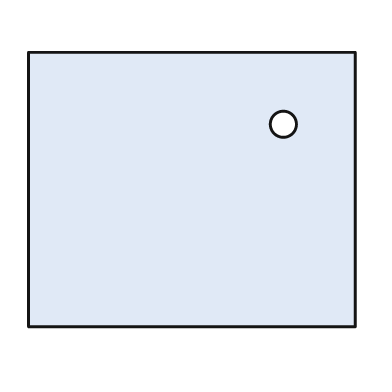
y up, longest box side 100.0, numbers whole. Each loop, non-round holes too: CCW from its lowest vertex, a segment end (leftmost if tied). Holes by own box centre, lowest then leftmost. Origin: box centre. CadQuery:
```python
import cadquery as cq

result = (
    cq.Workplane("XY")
    .moveTo(-50.0, -42.0)
    .lineTo(50.0, -42.0)
    .lineTo(50.0, 42.0)
    .lineTo(-50.0, 42.0)
    .close()
    .moveTo(28.0, 20.0)
    .circle(4.0)
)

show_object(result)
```